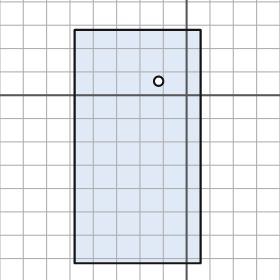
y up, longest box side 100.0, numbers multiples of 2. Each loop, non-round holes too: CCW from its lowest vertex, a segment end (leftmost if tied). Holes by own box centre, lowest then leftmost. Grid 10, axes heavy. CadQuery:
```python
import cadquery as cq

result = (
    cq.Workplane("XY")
    .moveTo(-48.0, -72.0)
    .lineTo(6.0, -72.0)
    .lineTo(6.0, 28.0)
    .lineTo(-48.0, 28.0)
    .close()
    .moveTo(-12.0, 6.0)
    .circle(2.0)
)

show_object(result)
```